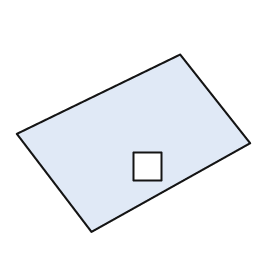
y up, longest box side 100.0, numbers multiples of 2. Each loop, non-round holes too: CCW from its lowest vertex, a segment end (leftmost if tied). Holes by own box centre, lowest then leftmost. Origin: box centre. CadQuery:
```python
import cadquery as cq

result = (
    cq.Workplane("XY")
    .moveTo(-18.0, -38.0)
    .lineTo(50.0, 0.0)
    .lineTo(20.0, 38.0)
    .lineTo(-50.0, 4.0)
    .close()
    .moveTo(0.0, -16.0)
    .lineTo(12.0, -16.0)
    .lineTo(12.0, -4.0)
    .lineTo(0.0, -4.0)
    .close()
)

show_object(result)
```